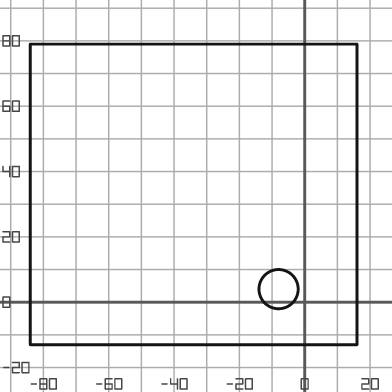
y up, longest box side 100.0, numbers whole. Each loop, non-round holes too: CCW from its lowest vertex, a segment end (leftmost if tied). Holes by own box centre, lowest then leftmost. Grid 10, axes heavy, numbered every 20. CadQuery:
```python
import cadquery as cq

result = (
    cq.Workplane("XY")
    .moveTo(-84.0, -13.0)
    .lineTo(16.0, -13.0)
    .lineTo(16.0, 79.0)
    .lineTo(-84.0, 79.0)
    .close()
    .moveTo(-8.0, 4.0)
    .circle(6.0)
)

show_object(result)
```